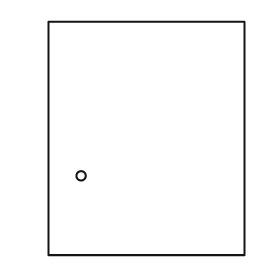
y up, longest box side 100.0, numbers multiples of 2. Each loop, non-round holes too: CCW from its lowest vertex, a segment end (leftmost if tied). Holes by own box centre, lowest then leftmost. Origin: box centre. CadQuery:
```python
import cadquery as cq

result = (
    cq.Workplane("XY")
    .moveTo(-42.0, -50.0)
    .lineTo(42.0, -50.0)
    .lineTo(42.0, 50.0)
    .lineTo(-42.0, 50.0)
    .close()
    .moveTo(-28.0, -16.0)
    .circle(2.0)
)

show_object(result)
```